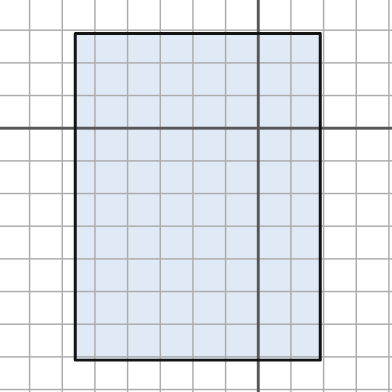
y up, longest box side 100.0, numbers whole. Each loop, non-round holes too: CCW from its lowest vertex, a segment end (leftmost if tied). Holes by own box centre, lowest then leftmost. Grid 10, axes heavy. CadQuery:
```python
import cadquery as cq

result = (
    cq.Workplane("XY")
    .moveTo(-56.0, -71.0)
    .lineTo(19.0, -71.0)
    .lineTo(19.0, 29.0)
    .lineTo(-56.0, 29.0)
    .close()
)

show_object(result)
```